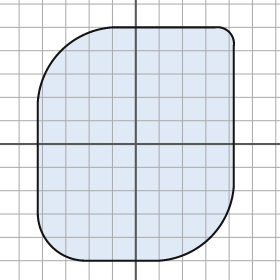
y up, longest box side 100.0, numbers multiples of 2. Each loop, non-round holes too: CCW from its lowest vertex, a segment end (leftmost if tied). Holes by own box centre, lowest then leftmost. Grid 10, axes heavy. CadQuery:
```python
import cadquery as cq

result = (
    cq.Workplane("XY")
    .moveTo(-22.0, -50.0)
    .lineTo(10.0, -50.0)
    .threePointArc((32.0, -40.0), (42.0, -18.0))
    .lineTo(42.0, 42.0)
    .threePointArc((40.0, 48.0), (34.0, 50.0))
    .lineTo(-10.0, 50.0)
    .threePointArc((-32.0, 40.0), (-42.0, 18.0))
    .lineTo(-42.0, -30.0)
    .threePointArc((-36.0, -44.0), (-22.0, -50.0))
    .close()
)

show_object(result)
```